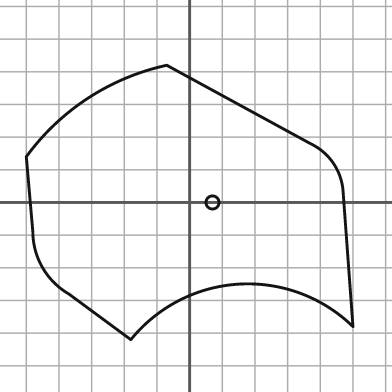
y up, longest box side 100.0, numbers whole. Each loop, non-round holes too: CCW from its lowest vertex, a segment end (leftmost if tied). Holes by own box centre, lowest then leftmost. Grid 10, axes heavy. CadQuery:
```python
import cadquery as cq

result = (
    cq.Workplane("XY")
    .moveTo(-18.0, -42.0)
    .threePointArc((15.0, -25.0), (50.0, -38.0))
    .lineTo(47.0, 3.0)
    .threePointArc((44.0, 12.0), (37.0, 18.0))
    .lineTo(-7.0, 42.0)
    .threePointArc((-31.0, 32.0), (-50.0, 14.0))
    .lineTo(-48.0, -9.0)
    .threePointArc((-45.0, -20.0), (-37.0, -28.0))
    .close()
    .moveTo(7.0, 0.0)
    .circle(2.0)
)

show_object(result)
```